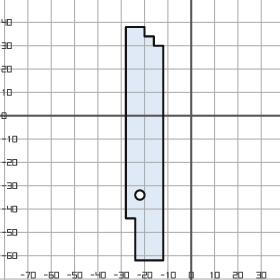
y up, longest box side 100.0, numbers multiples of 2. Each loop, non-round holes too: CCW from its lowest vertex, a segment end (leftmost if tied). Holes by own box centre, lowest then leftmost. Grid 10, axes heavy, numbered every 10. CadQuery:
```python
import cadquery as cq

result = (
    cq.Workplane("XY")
    .moveTo(-24.0, -62.0)
    .lineTo(-12.0, -62.0)
    .lineTo(-12.0, 30.0)
    .lineTo(-16.0, 30.0)
    .lineTo(-16.0, 34.0)
    .lineTo(-20.0, 34.0)
    .lineTo(-20.0, 38.0)
    .lineTo(-28.0, 38.0)
    .lineTo(-28.0, -44.0)
    .lineTo(-24.0, -44.0)
    .close()
    .moveTo(-22.0, -34.0)
    .circle(2.0)
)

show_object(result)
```